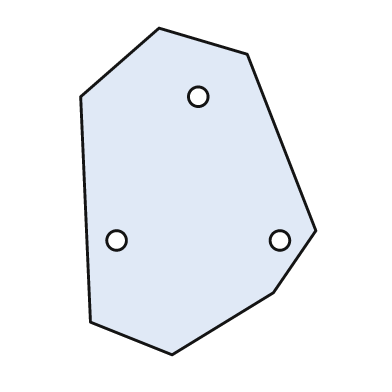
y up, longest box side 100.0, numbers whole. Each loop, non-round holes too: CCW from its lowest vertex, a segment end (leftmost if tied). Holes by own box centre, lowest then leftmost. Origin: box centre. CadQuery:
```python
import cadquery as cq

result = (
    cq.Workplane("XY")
    .moveTo(-8.0, -50.0)
    .lineTo(23.0, -31.0)
    .lineTo(36.0, -12.0)
    .lineTo(15.0, 42.0)
    .lineTo(-12.0, 50.0)
    .lineTo(-36.0, 29.0)
    .lineTo(-33.0, -40.0)
    .close()
    .moveTo(-25.0, -15.0)
    .circle(3.0)
    .moveTo(25.0, -15.0)
    .circle(3.0)
    .moveTo(0.0, 29.0)
    .circle(3.0)
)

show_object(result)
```